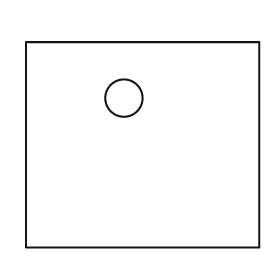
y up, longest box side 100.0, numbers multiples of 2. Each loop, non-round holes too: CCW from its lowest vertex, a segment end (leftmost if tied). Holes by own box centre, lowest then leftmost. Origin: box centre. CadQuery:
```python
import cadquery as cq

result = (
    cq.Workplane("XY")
    .moveTo(-50.0, -44.0)
    .lineTo(50.0, -44.0)
    .lineTo(50.0, 44.0)
    .lineTo(-50.0, 44.0)
    .close()
    .moveTo(-8.0, 20.0)
    .circle(8.0)
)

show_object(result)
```